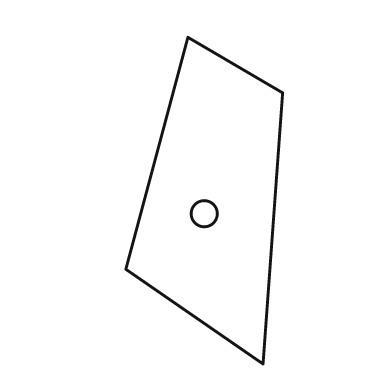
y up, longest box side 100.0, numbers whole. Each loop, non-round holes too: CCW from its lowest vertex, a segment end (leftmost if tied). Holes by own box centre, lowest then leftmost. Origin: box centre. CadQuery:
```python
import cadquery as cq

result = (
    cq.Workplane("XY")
    .moveTo(18.0, -50.0)
    .lineTo(24.0, 33.0)
    .lineTo(-5.0, 50.0)
    .lineTo(-24.0, -21.0)
    .close()
    .moveTo(0.0, -4.0)
    .circle(4.0)
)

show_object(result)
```